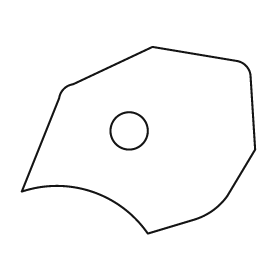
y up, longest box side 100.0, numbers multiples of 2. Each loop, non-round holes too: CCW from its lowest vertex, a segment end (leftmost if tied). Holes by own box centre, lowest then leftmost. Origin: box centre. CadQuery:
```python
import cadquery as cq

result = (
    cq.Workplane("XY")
    .moveTo(4.0, -40.0)
    .lineTo(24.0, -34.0)
    .threePointArc((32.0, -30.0), (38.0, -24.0))
    .lineTo(50.0, -4.0)
    .lineTo(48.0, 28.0)
    .threePointArc((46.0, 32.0), (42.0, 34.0))
    .lineTo(6.0, 40.0)
    .lineTo(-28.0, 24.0)
    .threePointArc((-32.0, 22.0), (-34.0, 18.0))
    .lineTo(-50.0, -22.0)
    .threePointArc((-20.0, -22.0), (4.0, -40.0))
    .close()
    .moveTo(-4.0, 4.0)
    .circle(8.0)
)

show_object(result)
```